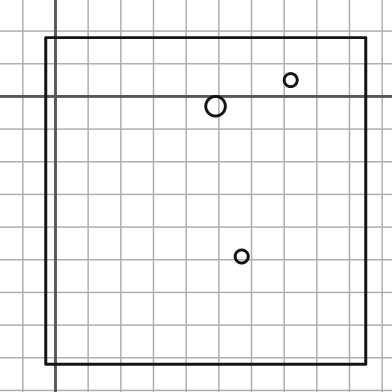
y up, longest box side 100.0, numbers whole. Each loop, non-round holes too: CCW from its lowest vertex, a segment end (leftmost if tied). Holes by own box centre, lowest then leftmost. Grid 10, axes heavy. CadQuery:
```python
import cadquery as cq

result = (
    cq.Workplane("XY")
    .moveTo(-3.0, -82.0)
    .lineTo(95.0, -82.0)
    .lineTo(95.0, 18.0)
    .lineTo(-3.0, 18.0)
    .close()
    .moveTo(57.0, -49.0)
    .circle(2.0)
    .moveTo(49.0, -3.0)
    .circle(3.0)
    .moveTo(72.0, 5.0)
    .circle(2.0)
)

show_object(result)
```